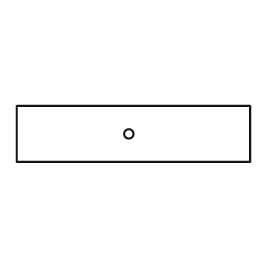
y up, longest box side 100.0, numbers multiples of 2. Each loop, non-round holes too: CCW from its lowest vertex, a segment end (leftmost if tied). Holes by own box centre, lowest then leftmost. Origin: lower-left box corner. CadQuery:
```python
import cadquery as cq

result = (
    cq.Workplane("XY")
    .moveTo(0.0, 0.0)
    .lineTo(100.0, 0.0)
    .lineTo(100.0, 24.0)
    .lineTo(0.0, 24.0)
    .close()
    .moveTo(48.0, 12.0)
    .circle(2.0)
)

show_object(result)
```